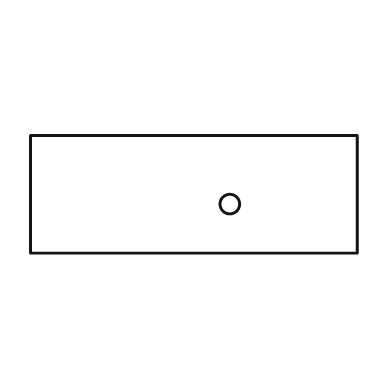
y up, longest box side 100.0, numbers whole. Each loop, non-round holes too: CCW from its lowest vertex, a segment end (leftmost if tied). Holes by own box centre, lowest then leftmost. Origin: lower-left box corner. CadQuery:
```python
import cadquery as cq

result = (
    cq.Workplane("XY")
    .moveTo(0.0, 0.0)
    .lineTo(100.0, 0.0)
    .lineTo(100.0, 36.0)
    .lineTo(0.0, 36.0)
    .close()
    .moveTo(61.0, 15.0)
    .circle(3.0)
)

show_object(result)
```